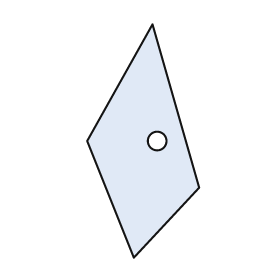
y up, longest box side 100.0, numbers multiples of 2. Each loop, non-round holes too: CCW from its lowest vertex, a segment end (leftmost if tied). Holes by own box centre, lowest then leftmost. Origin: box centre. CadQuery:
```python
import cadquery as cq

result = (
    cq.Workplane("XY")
    .moveTo(-4.0, -50.0)
    .lineTo(24.0, -20.0)
    .lineTo(4.0, 50.0)
    .lineTo(-24.0, 0.0)
    .close()
    .moveTo(6.0, 0.0)
    .circle(4.0)
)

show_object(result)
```